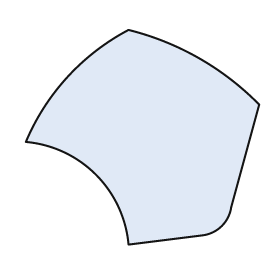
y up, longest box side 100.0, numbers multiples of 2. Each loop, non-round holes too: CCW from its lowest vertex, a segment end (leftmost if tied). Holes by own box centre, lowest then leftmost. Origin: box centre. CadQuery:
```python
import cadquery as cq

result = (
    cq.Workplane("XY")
    .moveTo(-6.0, -46.0)
    .lineTo(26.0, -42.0)
    .threePointArc((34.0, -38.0), (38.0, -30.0))
    .lineTo(50.0, 14.0)
    .threePointArc((24.0, 34.0), (-6.0, 46.0))
    .threePointArc((-32.0, 26.0), (-50.0, -2.0))
    .threePointArc((-20.0, -16.0), (-6.0, -46.0))
    .close()
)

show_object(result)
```